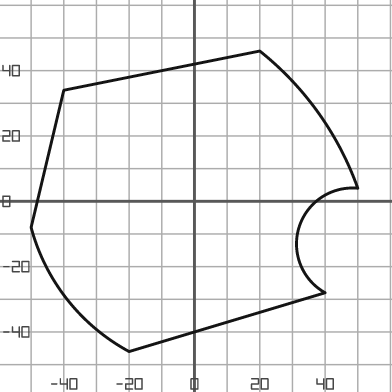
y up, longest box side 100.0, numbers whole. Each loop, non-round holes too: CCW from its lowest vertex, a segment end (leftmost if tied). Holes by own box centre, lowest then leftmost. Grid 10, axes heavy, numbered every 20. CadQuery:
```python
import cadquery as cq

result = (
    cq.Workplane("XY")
    .moveTo(-20.0, -46.0)
    .lineTo(40.0, -28.0)
    .threePointArc((32.0, -8.0), (50.0, 4.0))
    .threePointArc((38.0, 27.0), (20.0, 46.0))
    .lineTo(-40.0, 34.0)
    .lineTo(-50.0, -8.0)
    .threePointArc((-39.0, -30.0), (-20.0, -46.0))
    .close()
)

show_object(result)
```